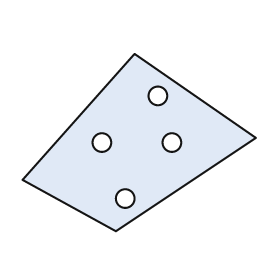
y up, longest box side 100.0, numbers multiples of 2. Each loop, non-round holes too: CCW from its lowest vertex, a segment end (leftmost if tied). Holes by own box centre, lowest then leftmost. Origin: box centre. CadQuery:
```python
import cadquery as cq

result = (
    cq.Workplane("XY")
    .moveTo(-10.0, -38.0)
    .lineTo(50.0, 2.0)
    .lineTo(-2.0, 38.0)
    .lineTo(-50.0, -16.0)
    .close()
    .moveTo(-6.0, -24.0)
    .circle(4.0)
    .moveTo(-16.0, 0.0)
    .circle(4.0)
    .moveTo(14.0, 0.0)
    .circle(4.0)
    .moveTo(8.0, 20.0)
    .circle(4.0)
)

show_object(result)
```